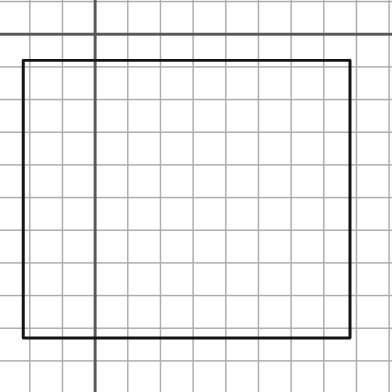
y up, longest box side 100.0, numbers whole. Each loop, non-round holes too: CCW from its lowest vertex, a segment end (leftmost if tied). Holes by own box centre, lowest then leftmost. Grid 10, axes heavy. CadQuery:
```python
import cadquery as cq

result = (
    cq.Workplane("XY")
    .moveTo(-22.0, -93.0)
    .lineTo(78.0, -93.0)
    .lineTo(78.0, -8.0)
    .lineTo(-22.0, -8.0)
    .close()
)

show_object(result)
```